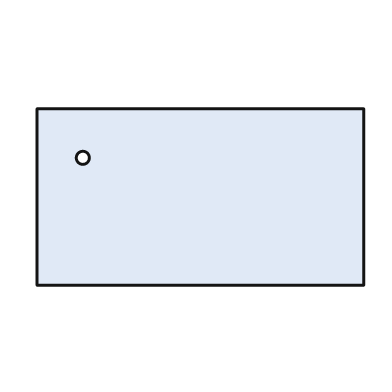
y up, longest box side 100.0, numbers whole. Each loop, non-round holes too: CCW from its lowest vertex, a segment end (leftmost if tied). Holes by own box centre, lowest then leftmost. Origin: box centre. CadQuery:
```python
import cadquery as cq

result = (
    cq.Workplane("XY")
    .moveTo(-50.0, -27.0)
    .lineTo(50.0, -27.0)
    .lineTo(50.0, 27.0)
    .lineTo(-50.0, 27.0)
    .close()
    .moveTo(-36.0, 12.0)
    .circle(2.0)
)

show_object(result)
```